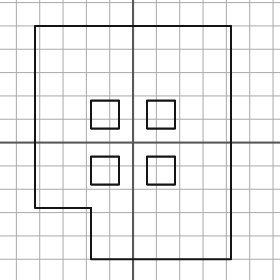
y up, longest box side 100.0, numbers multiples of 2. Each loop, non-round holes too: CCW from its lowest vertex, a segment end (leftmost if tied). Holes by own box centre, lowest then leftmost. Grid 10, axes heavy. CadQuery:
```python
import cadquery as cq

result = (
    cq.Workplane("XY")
    .moveTo(-18.0, -50.0)
    .lineTo(42.0, -50.0)
    .lineTo(42.0, 50.0)
    .lineTo(-42.0, 50.0)
    .lineTo(-42.0, -28.0)
    .lineTo(-18.0, -28.0)
    .close()
    .moveTo(-18.0, -18.0)
    .lineTo(-6.0, -18.0)
    .lineTo(-6.0, -6.0)
    .lineTo(-18.0, -6.0)
    .close()
    .moveTo(6.0, -18.0)
    .lineTo(18.0, -18.0)
    .lineTo(18.0, -6.0)
    .lineTo(6.0, -6.0)
    .close()
    .moveTo(-18.0, 6.0)
    .lineTo(-6.0, 6.0)
    .lineTo(-6.0, 18.0)
    .lineTo(-18.0, 18.0)
    .close()
    .moveTo(6.0, 6.0)
    .lineTo(18.0, 6.0)
    .lineTo(18.0, 18.0)
    .lineTo(6.0, 18.0)
    .close()
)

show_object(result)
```